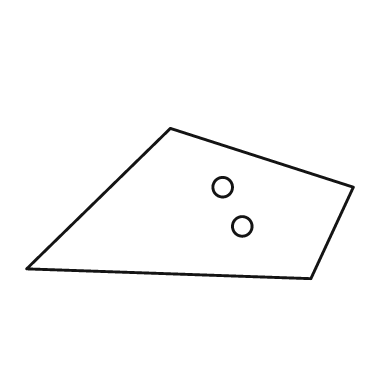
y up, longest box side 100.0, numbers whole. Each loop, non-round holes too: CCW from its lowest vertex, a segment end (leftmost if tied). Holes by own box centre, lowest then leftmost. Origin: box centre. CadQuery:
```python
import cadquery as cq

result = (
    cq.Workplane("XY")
    .moveTo(37.0, -23.0)
    .lineTo(50.0, 5.0)
    .lineTo(-6.0, 23.0)
    .lineTo(-50.0, -20.0)
    .close()
    .moveTo(16.0, -7.0)
    .circle(3.0)
    .moveTo(10.0, 5.0)
    .circle(3.0)
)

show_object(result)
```